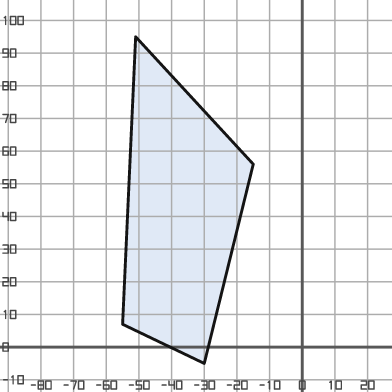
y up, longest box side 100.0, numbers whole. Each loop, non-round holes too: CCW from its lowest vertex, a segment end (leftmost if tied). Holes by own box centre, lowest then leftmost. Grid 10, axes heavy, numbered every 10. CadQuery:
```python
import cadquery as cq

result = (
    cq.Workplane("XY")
    .moveTo(-30.0, -5.0)
    .lineTo(-15.0, 56.0)
    .lineTo(-51.0, 95.0)
    .lineTo(-55.0, 7.0)
    .close()
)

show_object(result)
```